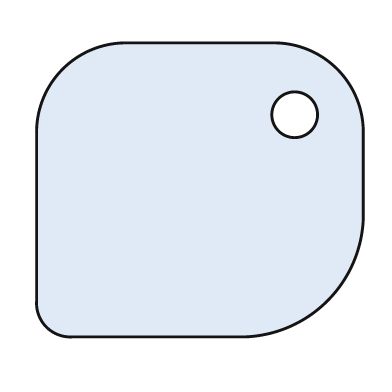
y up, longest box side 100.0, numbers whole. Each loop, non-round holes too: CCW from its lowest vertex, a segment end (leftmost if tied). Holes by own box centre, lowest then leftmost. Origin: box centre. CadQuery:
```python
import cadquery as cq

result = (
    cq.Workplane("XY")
    .moveTo(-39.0, -45.0)
    .lineTo(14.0, -45.0)
    .threePointArc((39.0, -34.0), (50.0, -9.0))
    .lineTo(50.0, 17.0)
    .threePointArc((42.0, 37.0), (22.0, 45.0))
    .lineTo(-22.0, 45.0)
    .threePointArc((-42.0, 37.0), (-50.0, 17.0))
    .lineTo(-50.0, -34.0)
    .threePointArc((-47.0, -42.0), (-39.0, -45.0))
    .close()
    .moveTo(29.0, 23.0)
    .circle(7.0)
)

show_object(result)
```